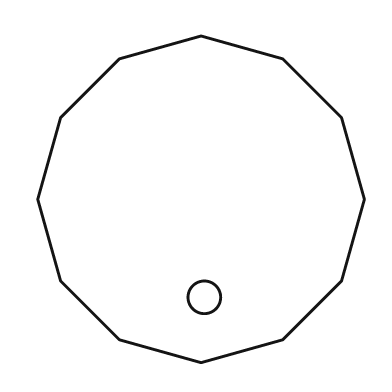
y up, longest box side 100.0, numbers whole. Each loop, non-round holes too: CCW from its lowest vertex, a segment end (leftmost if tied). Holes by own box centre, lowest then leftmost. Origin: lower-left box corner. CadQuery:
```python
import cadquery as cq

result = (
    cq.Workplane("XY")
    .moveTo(50.0, 0.0)
    .lineTo(75.0, 7.0)
    .lineTo(93.0, 25.0)
    .lineTo(100.0, 50.0)
    .lineTo(93.0, 75.0)
    .lineTo(75.0, 93.0)
    .lineTo(50.0, 100.0)
    .lineTo(25.0, 93.0)
    .lineTo(7.0, 75.0)
    .lineTo(0.0, 50.0)
    .lineTo(7.0, 25.0)
    .lineTo(25.0, 7.0)
    .close()
    .moveTo(51.0, 20.0)
    .circle(5.0)
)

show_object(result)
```